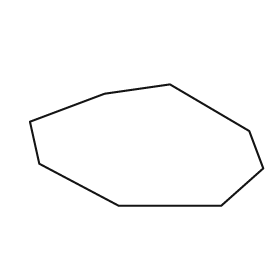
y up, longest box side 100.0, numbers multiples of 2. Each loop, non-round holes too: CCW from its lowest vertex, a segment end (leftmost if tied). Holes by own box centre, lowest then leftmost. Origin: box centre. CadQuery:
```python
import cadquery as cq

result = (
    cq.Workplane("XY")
    .moveTo(-12.0, -26.0)
    .lineTo(32.0, -26.0)
    .lineTo(50.0, -10.0)
    .lineTo(44.0, 6.0)
    .lineTo(10.0, 26.0)
    .lineTo(-18.0, 22.0)
    .lineTo(-50.0, 10.0)
    .lineTo(-46.0, -8.0)
    .close()
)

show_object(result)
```